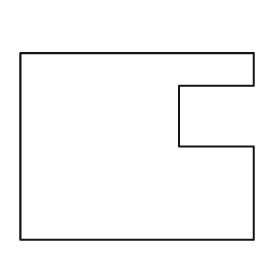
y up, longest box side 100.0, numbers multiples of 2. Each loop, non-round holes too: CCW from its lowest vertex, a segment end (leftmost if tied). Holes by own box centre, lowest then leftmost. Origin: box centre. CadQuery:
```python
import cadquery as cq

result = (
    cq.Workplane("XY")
    .moveTo(-50.0, -40.0)
    .lineTo(50.0, -40.0)
    .lineTo(50.0, 0.0)
    .lineTo(18.0, 0.0)
    .lineTo(18.0, 26.0)
    .lineTo(50.0, 26.0)
    .lineTo(50.0, 40.0)
    .lineTo(-50.0, 40.0)
    .close()
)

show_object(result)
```